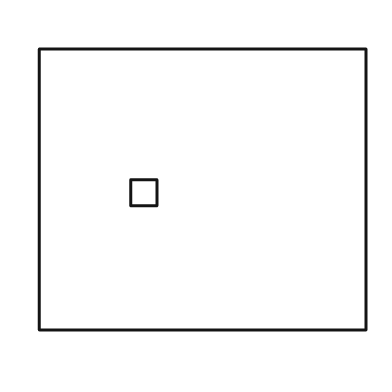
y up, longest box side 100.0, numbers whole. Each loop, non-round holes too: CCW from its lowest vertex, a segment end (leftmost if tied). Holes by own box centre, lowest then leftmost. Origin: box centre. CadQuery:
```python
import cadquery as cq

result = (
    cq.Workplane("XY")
    .moveTo(-50.0, -43.0)
    .lineTo(50.0, -43.0)
    .lineTo(50.0, 43.0)
    .lineTo(-50.0, 43.0)
    .close()
    .moveTo(-22.0, -5.0)
    .lineTo(-14.0, -5.0)
    .lineTo(-14.0, 3.0)
    .lineTo(-22.0, 3.0)
    .close()
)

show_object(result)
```